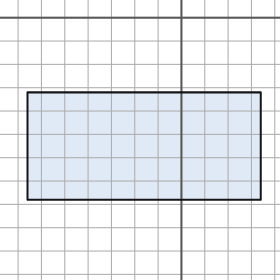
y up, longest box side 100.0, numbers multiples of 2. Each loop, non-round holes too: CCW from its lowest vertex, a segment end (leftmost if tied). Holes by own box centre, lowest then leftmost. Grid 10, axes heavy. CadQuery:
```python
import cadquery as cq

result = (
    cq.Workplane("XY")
    .moveTo(-66.0, -78.0)
    .lineTo(34.0, -78.0)
    .lineTo(34.0, -32.0)
    .lineTo(-66.0, -32.0)
    .close()
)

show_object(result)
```